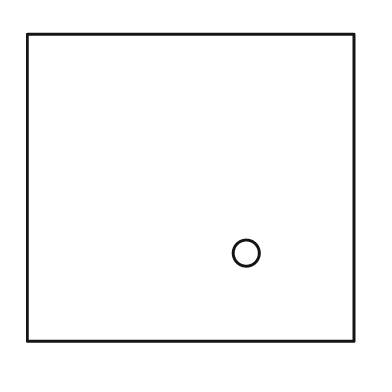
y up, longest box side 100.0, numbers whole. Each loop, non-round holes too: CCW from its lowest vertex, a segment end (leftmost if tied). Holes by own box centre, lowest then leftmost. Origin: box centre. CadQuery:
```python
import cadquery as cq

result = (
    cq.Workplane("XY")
    .moveTo(-50.0, -47.0)
    .lineTo(50.0, -47.0)
    .lineTo(50.0, 47.0)
    .lineTo(-50.0, 47.0)
    .close()
    .moveTo(17.0, -20.0)
    .circle(4.0)
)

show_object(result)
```